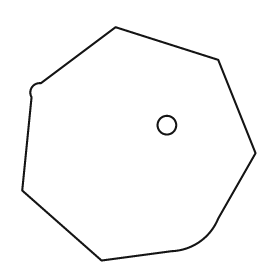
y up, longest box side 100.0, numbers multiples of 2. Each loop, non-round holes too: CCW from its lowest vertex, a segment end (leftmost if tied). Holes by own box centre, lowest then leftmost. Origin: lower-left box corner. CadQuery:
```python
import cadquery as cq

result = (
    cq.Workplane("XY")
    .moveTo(34.0, 0.0)
    .lineTo(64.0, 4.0)
    .threePointArc((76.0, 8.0), (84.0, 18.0))
    .lineTo(100.0, 46.0)
    .lineTo(84.0, 86.0)
    .lineTo(40.0, 100.0)
    .lineTo(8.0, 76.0)
    .threePointArc((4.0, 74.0), (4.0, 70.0))
    .lineTo(0.0, 30.0)
    .close()
    .moveTo(62.0, 58.0)
    .circle(4.0)
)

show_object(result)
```